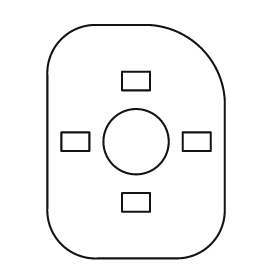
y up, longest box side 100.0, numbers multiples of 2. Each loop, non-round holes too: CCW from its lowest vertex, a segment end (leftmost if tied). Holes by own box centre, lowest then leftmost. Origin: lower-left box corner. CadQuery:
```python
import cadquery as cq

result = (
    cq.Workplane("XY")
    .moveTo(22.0, 0.0)
    .lineTo(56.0, 0.0)
    .threePointArc((70.0, 6.0), (76.0, 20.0))
    .lineTo(76.0, 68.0)
    .threePointArc((66.0, 90.0), (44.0, 100.0))
    .lineTo(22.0, 100.0)
    .threePointArc((6.0, 94.0), (0.0, 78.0))
    .lineTo(0.0, 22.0)
    .threePointArc((6.0, 6.0), (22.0, 0.0))
    .close()
    .moveTo(32.0, 20.0)
    .lineTo(44.0, 20.0)
    .lineTo(44.0, 28.0)
    .lineTo(32.0, 28.0)
    .close()
    .moveTo(6.0, 46.0)
    .lineTo(18.0, 46.0)
    .lineTo(18.0, 54.0)
    .lineTo(6.0, 54.0)
    .close()
    .moveTo(38.0, 50.0)
    .circle(14.0)
    .moveTo(58.0, 46.0)
    .lineTo(70.0, 46.0)
    .lineTo(70.0, 54.0)
    .lineTo(58.0, 54.0)
    .close()
    .moveTo(32.0, 72.0)
    .lineTo(44.0, 72.0)
    .lineTo(44.0, 80.0)
    .lineTo(32.0, 80.0)
    .close()
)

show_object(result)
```